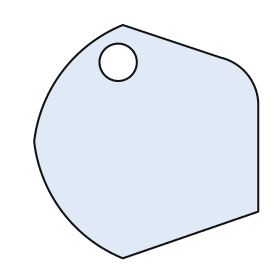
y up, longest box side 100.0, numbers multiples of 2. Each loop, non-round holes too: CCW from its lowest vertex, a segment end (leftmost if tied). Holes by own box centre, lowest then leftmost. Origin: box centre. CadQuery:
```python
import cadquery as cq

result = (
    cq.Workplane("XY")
    .moveTo(-10.0, -50.0)
    .lineTo(48.0, -30.0)
    .lineTo(48.0, 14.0)
    .threePointArc((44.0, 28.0), (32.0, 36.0))
    .lineTo(-10.0, 50.0)
    .threePointArc((-36.0, 30.0), (-48.0, 0.0))
    .threePointArc((-36.0, -30.0), (-10.0, -50.0))
    .close()
    .moveTo(-12.0, 34.0)
    .circle(8.0)
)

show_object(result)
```